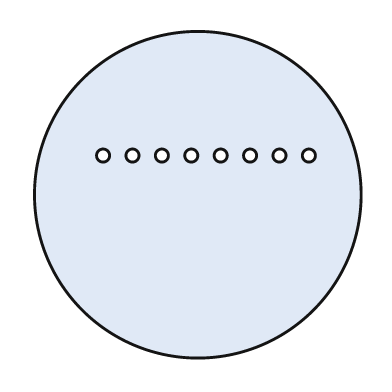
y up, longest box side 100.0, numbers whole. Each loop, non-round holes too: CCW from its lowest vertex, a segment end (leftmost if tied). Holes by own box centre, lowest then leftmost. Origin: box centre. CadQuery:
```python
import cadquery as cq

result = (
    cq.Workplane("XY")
    .moveTo(0.0, 0.0)
    .circle(50.0)
    .moveTo(-29.0, 12.0)
    .circle(2.0)
    .moveTo(-20.0, 12.0)
    .circle(2.0)
    .moveTo(-11.0, 12.0)
    .circle(2.0)
    .moveTo(-2.0, 12.0)
    .circle(2.0)
    .moveTo(7.0, 12.0)
    .circle(2.0)
    .moveTo(16.0, 12.0)
    .circle(2.0)
    .moveTo(25.0, 12.0)
    .circle(2.0)
    .moveTo(34.0, 12.0)
    .circle(2.0)
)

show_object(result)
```